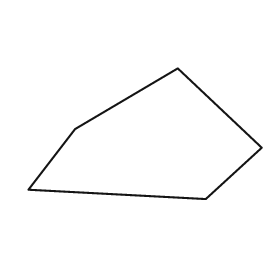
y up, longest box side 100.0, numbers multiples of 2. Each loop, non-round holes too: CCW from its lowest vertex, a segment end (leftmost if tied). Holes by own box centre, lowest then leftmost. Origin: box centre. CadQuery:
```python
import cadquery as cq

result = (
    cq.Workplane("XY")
    .moveTo(26.0, -28.0)
    .lineTo(50.0, -6.0)
    .lineTo(14.0, 28.0)
    .lineTo(-30.0, 2.0)
    .lineTo(-50.0, -24.0)
    .close()
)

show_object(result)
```